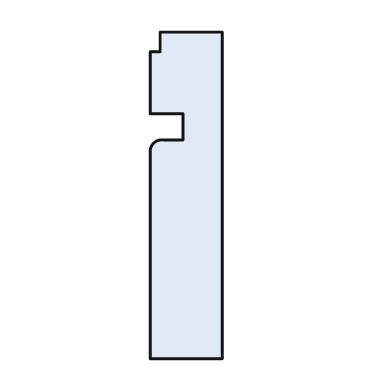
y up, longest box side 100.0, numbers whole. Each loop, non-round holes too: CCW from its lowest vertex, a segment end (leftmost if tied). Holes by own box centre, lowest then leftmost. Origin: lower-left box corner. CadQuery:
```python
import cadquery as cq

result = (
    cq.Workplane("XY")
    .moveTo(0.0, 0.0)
    .lineTo(22.0, 0.0)
    .lineTo(22.0, 100.0)
    .lineTo(3.0, 100.0)
    .lineTo(3.0, 94.0)
    .lineTo(0.0, 94.0)
    .lineTo(0.0, 75.0)
    .lineTo(10.0, 75.0)
    .lineTo(10.0, 67.0)
    .lineTo(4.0, 67.0)
    .threePointArc((1.0, 66.0), (0.0, 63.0))
    .close()
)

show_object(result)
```